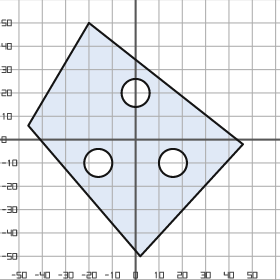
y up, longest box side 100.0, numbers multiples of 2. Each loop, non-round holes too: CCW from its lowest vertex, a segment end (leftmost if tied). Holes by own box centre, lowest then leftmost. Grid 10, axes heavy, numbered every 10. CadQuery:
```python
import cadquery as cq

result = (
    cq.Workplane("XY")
    .moveTo(2.0, -50.0)
    .lineTo(46.0, -2.0)
    .lineTo(-20.0, 50.0)
    .lineTo(-46.0, 6.0)
    .close()
    .moveTo(-16.0, -10.0)
    .circle(6.0)
    .moveTo(16.0, -10.0)
    .circle(6.0)
    .moveTo(0.0, 20.0)
    .circle(6.0)
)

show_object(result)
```